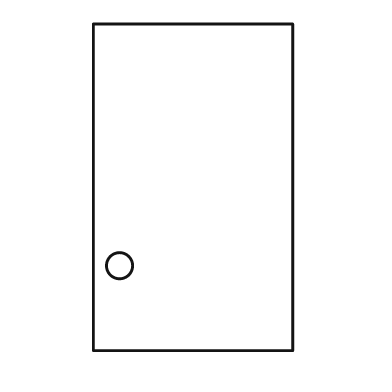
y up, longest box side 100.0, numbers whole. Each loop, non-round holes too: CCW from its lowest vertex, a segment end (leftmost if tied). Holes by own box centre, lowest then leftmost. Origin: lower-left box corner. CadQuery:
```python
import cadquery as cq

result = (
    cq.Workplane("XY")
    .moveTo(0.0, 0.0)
    .lineTo(61.0, 0.0)
    .lineTo(61.0, 100.0)
    .lineTo(0.0, 100.0)
    .close()
    .moveTo(8.0, 26.0)
    .circle(4.0)
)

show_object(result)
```